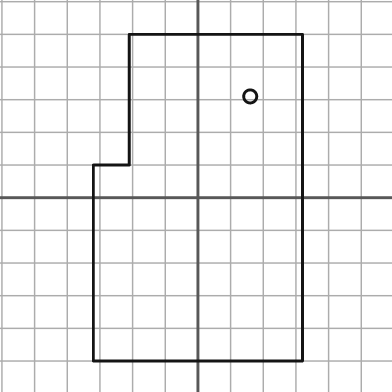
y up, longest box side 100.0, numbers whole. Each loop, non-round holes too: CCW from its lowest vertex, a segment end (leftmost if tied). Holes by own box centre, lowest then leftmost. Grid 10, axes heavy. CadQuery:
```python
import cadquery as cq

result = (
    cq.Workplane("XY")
    .moveTo(-32.0, -50.0)
    .lineTo(32.0, -50.0)
    .lineTo(32.0, 50.0)
    .lineTo(-21.0, 50.0)
    .lineTo(-21.0, 10.0)
    .lineTo(-32.0, 10.0)
    .close()
    .moveTo(16.0, 31.0)
    .circle(2.0)
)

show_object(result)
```